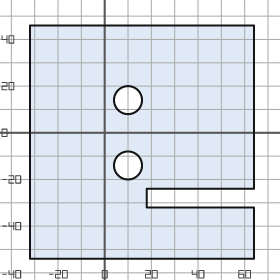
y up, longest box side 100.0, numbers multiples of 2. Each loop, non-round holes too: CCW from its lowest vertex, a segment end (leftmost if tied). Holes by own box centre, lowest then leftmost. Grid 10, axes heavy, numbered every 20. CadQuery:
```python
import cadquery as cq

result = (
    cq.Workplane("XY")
    .moveTo(-32.0, -54.0)
    .lineTo(64.0, -54.0)
    .lineTo(64.0, -32.0)
    .lineTo(18.0, -32.0)
    .lineTo(18.0, -24.0)
    .lineTo(64.0, -24.0)
    .lineTo(64.0, 46.0)
    .lineTo(-32.0, 46.0)
    .close()
    .moveTo(10.0, -14.0)
    .circle(6.0)
    .moveTo(10.0, 14.0)
    .circle(6.0)
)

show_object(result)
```